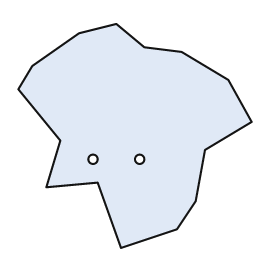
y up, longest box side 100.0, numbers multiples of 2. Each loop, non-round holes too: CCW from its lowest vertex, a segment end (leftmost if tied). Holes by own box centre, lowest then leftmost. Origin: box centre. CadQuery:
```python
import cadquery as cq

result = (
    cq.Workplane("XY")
    .moveTo(-6.0, -48.0)
    .lineTo(18.0, -40.0)
    .lineTo(26.0, -28.0)
    .lineTo(30.0, -6.0)
    .lineTo(50.0, 6.0)
    .lineTo(40.0, 24.0)
    .lineTo(20.0, 36.0)
    .lineTo(4.0, 38.0)
    .lineTo(-8.0, 48.0)
    .lineTo(-24.0, 44.0)
    .lineTo(-44.0, 30.0)
    .lineTo(-50.0, 20.0)
    .lineTo(-32.0, -2.0)
    .lineTo(-38.0, -22.0)
    .lineTo(-16.0, -20.0)
    .close()
    .moveTo(-18.0, -10.0)
    .circle(2.0)
    .moveTo(2.0, -10.0)
    .circle(2.0)
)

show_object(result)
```